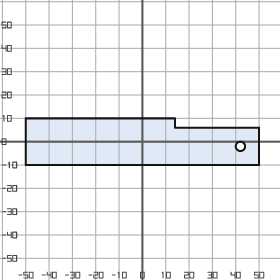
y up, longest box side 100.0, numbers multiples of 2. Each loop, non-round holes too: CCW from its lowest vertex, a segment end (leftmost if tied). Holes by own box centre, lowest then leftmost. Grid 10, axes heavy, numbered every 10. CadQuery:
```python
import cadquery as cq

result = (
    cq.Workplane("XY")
    .moveTo(-50.0, -10.0)
    .lineTo(50.0, -10.0)
    .lineTo(50.0, 6.0)
    .lineTo(14.0, 6.0)
    .lineTo(14.0, 10.0)
    .lineTo(-50.0, 10.0)
    .close()
    .moveTo(42.0, -2.0)
    .circle(2.0)
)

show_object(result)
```